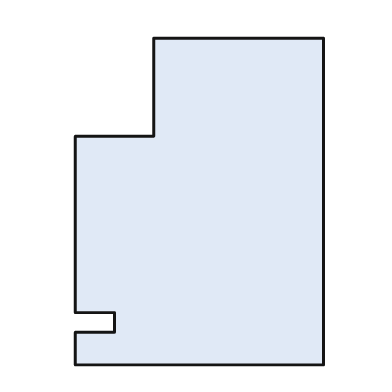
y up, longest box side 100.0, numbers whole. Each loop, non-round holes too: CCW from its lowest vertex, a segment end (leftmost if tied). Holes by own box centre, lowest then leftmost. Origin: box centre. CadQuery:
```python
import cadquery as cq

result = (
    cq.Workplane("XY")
    .moveTo(-38.0, -50.0)
    .lineTo(38.0, -50.0)
    .lineTo(38.0, 50.0)
    .lineTo(-14.0, 50.0)
    .lineTo(-14.0, 20.0)
    .lineTo(-38.0, 20.0)
    .lineTo(-38.0, -34.0)
    .lineTo(-26.0, -34.0)
    .lineTo(-26.0, -40.0)
    .lineTo(-38.0, -40.0)
    .close()
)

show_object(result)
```